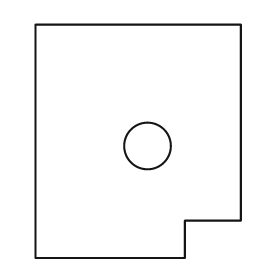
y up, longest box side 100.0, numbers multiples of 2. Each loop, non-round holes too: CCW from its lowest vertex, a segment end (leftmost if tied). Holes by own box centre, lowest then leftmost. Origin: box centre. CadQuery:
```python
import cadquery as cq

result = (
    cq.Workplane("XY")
    .moveTo(-44.0, -50.0)
    .lineTo(20.0, -50.0)
    .lineTo(20.0, -34.0)
    .lineTo(44.0, -34.0)
    .lineTo(44.0, 50.0)
    .lineTo(-44.0, 50.0)
    .close()
    .moveTo(4.0, -2.0)
    .circle(10.0)
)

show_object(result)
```